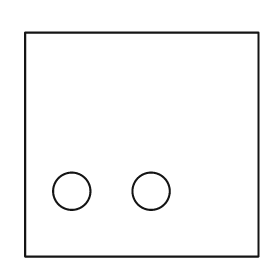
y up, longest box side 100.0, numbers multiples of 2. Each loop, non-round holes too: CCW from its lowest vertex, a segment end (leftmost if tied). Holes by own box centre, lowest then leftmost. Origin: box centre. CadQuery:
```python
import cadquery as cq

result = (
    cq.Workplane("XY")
    .moveTo(-50.0, -48.0)
    .lineTo(50.0, -48.0)
    .lineTo(50.0, 48.0)
    .lineTo(-50.0, 48.0)
    .close()
    .moveTo(-30.0, -20.0)
    .circle(8.0)
    .moveTo(4.0, -20.0)
    .circle(8.0)
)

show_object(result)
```